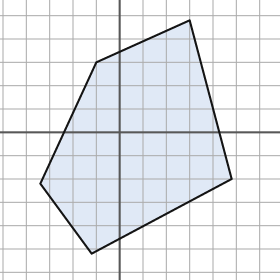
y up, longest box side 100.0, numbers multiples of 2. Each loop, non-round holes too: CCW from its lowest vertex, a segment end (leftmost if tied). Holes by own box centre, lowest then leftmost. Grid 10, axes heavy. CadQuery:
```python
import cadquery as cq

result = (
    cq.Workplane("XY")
    .moveTo(-12.0, -52.0)
    .lineTo(48.0, -20.0)
    .lineTo(30.0, 48.0)
    .lineTo(-10.0, 30.0)
    .lineTo(-34.0, -22.0)
    .close()
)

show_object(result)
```